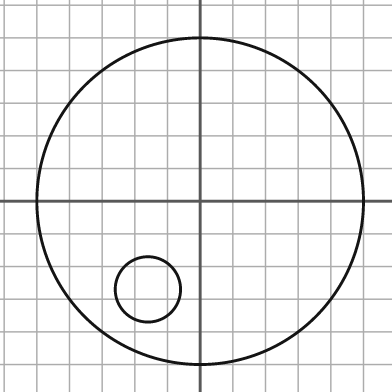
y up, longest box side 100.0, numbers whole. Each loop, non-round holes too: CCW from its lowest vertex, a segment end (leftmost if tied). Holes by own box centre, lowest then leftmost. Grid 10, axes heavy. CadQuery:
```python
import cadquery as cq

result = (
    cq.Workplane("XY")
    .moveTo(0.0, 0.0)
    .circle(50.0)
    .moveTo(-16.0, -27.0)
    .circle(10.0)
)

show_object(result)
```